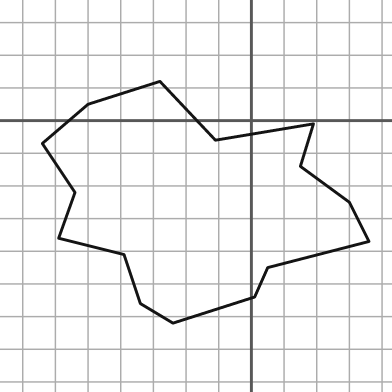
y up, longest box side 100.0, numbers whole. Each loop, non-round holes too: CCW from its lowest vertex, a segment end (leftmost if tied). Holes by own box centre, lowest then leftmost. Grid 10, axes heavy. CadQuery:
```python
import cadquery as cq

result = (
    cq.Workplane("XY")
    .moveTo(-24.0, -62.0)
    .lineTo(1.0, -54.0)
    .lineTo(5.0, -45.0)
    .lineTo(36.0, -37.0)
    .lineTo(30.0, -25.0)
    .lineTo(15.0, -14.0)
    .lineTo(19.0, -1.0)
    .lineTo(-11.0, -6.0)
    .lineTo(-28.0, 12.0)
    .lineTo(-50.0, 5.0)
    .lineTo(-64.0, -7.0)
    .lineTo(-54.0, -22.0)
    .lineTo(-59.0, -36.0)
    .lineTo(-39.0, -41.0)
    .lineTo(-34.0, -56.0)
    .close()
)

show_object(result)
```